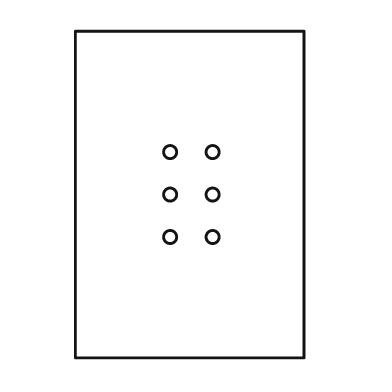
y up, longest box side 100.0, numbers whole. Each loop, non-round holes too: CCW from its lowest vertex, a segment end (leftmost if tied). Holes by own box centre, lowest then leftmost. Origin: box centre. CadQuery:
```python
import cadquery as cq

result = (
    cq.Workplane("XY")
    .moveTo(-35.0, -50.0)
    .lineTo(35.0, -50.0)
    .lineTo(35.0, 50.0)
    .lineTo(-35.0, 50.0)
    .close()
    .moveTo(-6.0, -13.0)
    .circle(2.0)
    .moveTo(7.0, -13.0)
    .circle(2.0)
    .moveTo(-6.0, 0.0)
    .circle(2.0)
    .moveTo(7.0, 0.0)
    .circle(2.0)
    .moveTo(-6.0, 13.0)
    .circle(2.0)
    .moveTo(7.0, 13.0)
    .circle(2.0)
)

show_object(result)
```